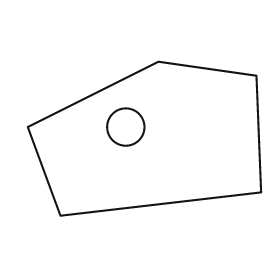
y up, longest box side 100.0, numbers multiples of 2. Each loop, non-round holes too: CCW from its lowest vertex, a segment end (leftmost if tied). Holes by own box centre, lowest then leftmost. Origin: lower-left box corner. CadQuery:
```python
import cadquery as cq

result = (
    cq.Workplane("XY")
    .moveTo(14.0, 0.0)
    .lineTo(100.0, 10.0)
    .lineTo(98.0, 60.0)
    .lineTo(56.0, 66.0)
    .lineTo(0.0, 38.0)
    .close()
    .moveTo(42.0, 38.0)
    .circle(8.0)
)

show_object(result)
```